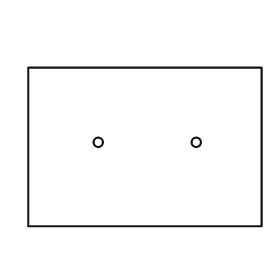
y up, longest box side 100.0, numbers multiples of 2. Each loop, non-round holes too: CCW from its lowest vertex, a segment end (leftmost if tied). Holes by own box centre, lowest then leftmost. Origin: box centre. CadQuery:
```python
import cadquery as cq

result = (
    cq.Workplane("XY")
    .moveTo(-50.0, -34.0)
    .lineTo(50.0, -34.0)
    .lineTo(50.0, 34.0)
    .lineTo(-50.0, 34.0)
    .close()
    .moveTo(-20.0, 2.0)
    .circle(2.0)
    .moveTo(22.0, 2.0)
    .circle(2.0)
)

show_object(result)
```